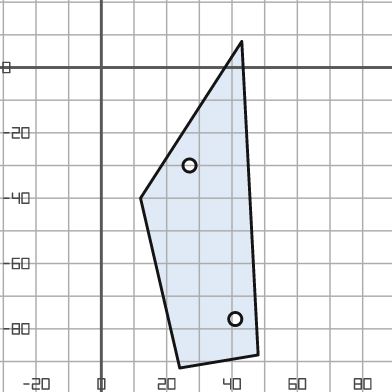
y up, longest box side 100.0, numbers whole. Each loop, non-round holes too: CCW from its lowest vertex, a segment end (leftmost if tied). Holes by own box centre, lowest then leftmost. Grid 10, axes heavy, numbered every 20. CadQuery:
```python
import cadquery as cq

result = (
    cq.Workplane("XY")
    .moveTo(24.0, -92.0)
    .lineTo(48.0, -88.0)
    .lineTo(43.0, 8.0)
    .lineTo(12.0, -40.0)
    .close()
    .moveTo(41.0, -77.0)
    .circle(2.0)
    .moveTo(27.0, -30.0)
    .circle(2.0)
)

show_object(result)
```